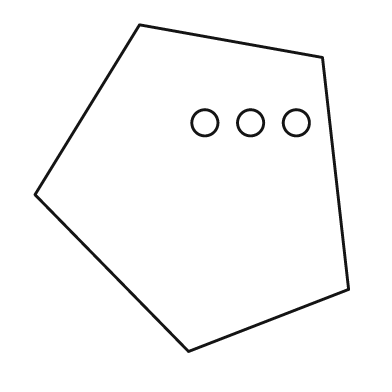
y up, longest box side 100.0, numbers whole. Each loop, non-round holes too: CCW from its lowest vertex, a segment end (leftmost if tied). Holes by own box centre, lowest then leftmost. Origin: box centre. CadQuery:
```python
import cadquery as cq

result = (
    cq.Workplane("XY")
    .moveTo(-1.0, -50.0)
    .lineTo(48.0, -31.0)
    .lineTo(40.0, 40.0)
    .lineTo(-16.0, 50.0)
    .lineTo(-48.0, -2.0)
    .close()
    .moveTo(4.0, 20.0)
    .circle(4.0)
    .moveTo(18.0, 20.0)
    .circle(4.0)
    .moveTo(32.0, 20.0)
    .circle(4.0)
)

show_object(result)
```